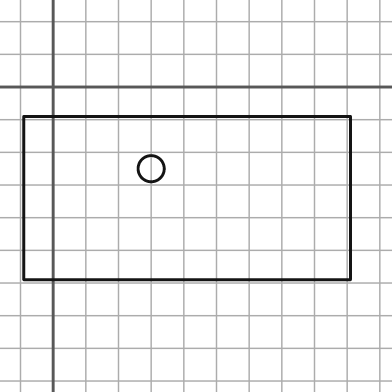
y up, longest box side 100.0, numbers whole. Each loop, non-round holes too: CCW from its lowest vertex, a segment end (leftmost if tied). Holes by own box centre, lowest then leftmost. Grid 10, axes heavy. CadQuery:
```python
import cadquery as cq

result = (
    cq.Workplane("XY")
    .moveTo(-9.0, -59.0)
    .lineTo(91.0, -59.0)
    .lineTo(91.0, -9.0)
    .lineTo(-9.0, -9.0)
    .close()
    .moveTo(30.0, -25.0)
    .circle(4.0)
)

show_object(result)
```